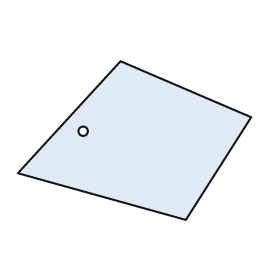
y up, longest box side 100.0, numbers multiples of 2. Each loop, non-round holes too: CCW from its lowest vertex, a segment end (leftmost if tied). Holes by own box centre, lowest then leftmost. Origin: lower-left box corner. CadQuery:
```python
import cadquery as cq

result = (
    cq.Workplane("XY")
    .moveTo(72.0, 0.0)
    .lineTo(100.0, 44.0)
    .lineTo(44.0, 68.0)
    .lineTo(0.0, 20.0)
    .close()
    .moveTo(28.0, 38.0)
    .circle(2.0)
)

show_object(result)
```